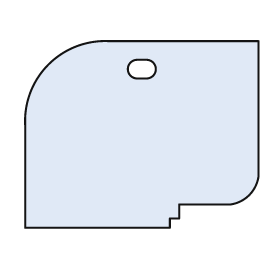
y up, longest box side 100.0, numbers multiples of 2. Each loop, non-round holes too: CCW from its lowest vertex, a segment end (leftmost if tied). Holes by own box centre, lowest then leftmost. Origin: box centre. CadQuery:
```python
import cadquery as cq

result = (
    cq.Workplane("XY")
    .moveTo(-50.0, -40.0)
    .lineTo(12.0, -40.0)
    .lineTo(12.0, -36.0)
    .lineTo(16.0, -36.0)
    .lineTo(16.0, -30.0)
    .lineTo(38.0, -30.0)
    .threePointArc((46.0, -26.0), (50.0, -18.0))
    .lineTo(50.0, 40.0)
    .lineTo(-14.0, 40.0)
    .threePointArc((-40.0, 30.0), (-50.0, 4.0))
    .close()
    .moveTo(-2.0, 24.0)
    .lineTo(2.0, 24.0)
    .threePointArc((6.0, 28.0), (2.0, 32.0))
    .lineTo(-2.0, 32.0)
    .threePointArc((-6.0, 28.0), (-2.0, 24.0))
    .close()
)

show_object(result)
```